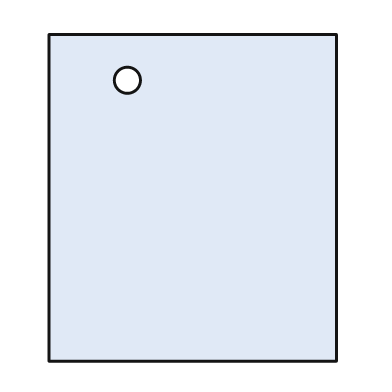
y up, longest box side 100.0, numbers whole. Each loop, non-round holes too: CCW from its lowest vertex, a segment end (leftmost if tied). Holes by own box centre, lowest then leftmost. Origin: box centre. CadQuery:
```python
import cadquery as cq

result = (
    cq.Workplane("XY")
    .moveTo(-44.0, -50.0)
    .lineTo(44.0, -50.0)
    .lineTo(44.0, 50.0)
    .lineTo(-44.0, 50.0)
    .close()
    .moveTo(-20.0, 36.0)
    .circle(4.0)
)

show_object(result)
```